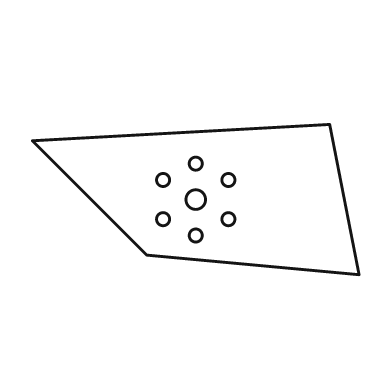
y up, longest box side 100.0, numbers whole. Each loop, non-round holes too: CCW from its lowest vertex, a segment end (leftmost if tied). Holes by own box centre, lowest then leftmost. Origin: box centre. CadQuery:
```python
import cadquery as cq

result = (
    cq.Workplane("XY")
    .moveTo(50.0, -23.0)
    .lineTo(41.0, 23.0)
    .lineTo(-50.0, 18.0)
    .lineTo(-15.0, -17.0)
    .close()
    .moveTo(0.0, -11.0)
    .circle(2.0)
    .moveTo(-10.0, -6.0)
    .circle(2.0)
    .moveTo(10.0, -6.0)
    .circle(2.0)
    .moveTo(0.0, 0.0)
    .circle(3.0)
    .moveTo(-10.0, 6.0)
    .circle(2.0)
    .moveTo(10.0, 6.0)
    .circle(2.0)
    .moveTo(0.0, 11.0)
    .circle(2.0)
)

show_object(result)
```